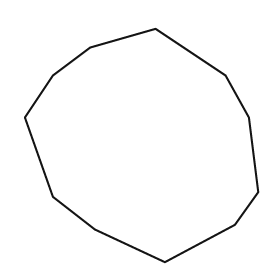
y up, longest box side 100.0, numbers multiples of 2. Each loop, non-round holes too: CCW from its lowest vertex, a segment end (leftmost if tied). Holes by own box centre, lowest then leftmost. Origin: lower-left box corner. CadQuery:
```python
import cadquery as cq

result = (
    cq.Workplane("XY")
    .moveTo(60.0, 0.0)
    .lineTo(90.0, 16.0)
    .lineTo(100.0, 30.0)
    .lineTo(96.0, 62.0)
    .lineTo(86.0, 80.0)
    .lineTo(56.0, 100.0)
    .lineTo(28.0, 92.0)
    .lineTo(12.0, 80.0)
    .lineTo(0.0, 62.0)
    .lineTo(12.0, 28.0)
    .lineTo(30.0, 14.0)
    .close()
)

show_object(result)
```